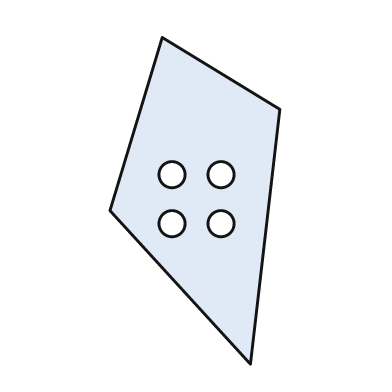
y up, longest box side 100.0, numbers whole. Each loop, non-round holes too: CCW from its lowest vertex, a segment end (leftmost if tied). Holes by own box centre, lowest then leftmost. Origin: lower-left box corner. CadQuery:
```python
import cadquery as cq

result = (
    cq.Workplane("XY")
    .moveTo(43.0, 0.0)
    .lineTo(52.0, 78.0)
    .lineTo(16.0, 100.0)
    .lineTo(0.0, 47.0)
    .close()
    .moveTo(19.0, 43.0)
    .circle(4.0)
    .moveTo(34.0, 43.0)
    .circle(4.0)
    .moveTo(19.0, 58.0)
    .circle(4.0)
    .moveTo(34.0, 58.0)
    .circle(4.0)
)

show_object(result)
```